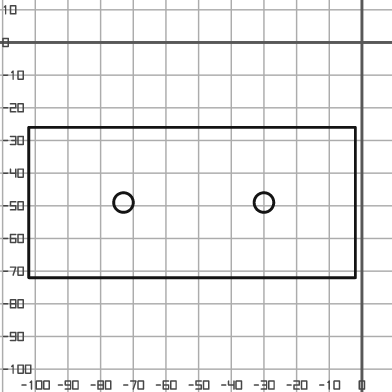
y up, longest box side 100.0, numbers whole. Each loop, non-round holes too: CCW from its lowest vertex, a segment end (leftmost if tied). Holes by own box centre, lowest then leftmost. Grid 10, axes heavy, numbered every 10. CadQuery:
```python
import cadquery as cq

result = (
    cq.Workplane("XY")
    .moveTo(-102.0, -72.0)
    .lineTo(-2.0, -72.0)
    .lineTo(-2.0, -26.0)
    .lineTo(-102.0, -26.0)
    .close()
    .moveTo(-73.0, -49.0)
    .circle(3.0)
    .moveTo(-30.0, -49.0)
    .circle(3.0)
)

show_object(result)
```